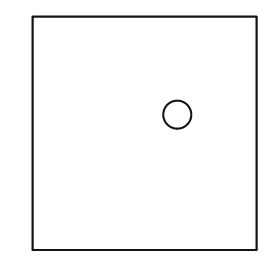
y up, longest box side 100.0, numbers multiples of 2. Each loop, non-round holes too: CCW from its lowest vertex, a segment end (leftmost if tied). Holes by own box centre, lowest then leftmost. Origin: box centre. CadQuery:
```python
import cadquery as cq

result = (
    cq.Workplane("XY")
    .moveTo(-48.0, -50.0)
    .lineTo(48.0, -50.0)
    .lineTo(48.0, 50.0)
    .lineTo(-48.0, 50.0)
    .close()
    .moveTo(14.0, 8.0)
    .circle(6.0)
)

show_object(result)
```